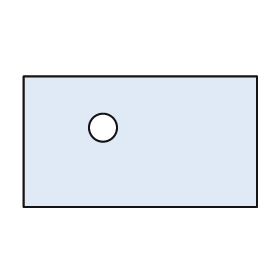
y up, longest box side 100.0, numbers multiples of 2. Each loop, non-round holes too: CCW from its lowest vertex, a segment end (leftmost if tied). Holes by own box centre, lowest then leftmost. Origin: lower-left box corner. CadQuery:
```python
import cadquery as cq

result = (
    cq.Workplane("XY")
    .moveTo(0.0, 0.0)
    .lineTo(100.0, 0.0)
    .lineTo(100.0, 56.0)
    .lineTo(0.0, 56.0)
    .close()
    .moveTo(34.0, 34.0)
    .circle(6.0)
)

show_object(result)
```